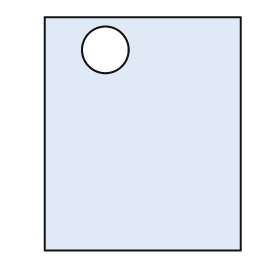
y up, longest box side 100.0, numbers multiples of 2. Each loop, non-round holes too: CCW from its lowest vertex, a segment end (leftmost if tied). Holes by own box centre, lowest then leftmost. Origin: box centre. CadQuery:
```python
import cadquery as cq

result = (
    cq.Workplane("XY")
    .moveTo(-42.0, -50.0)
    .lineTo(42.0, -50.0)
    .lineTo(42.0, 50.0)
    .lineTo(-42.0, 50.0)
    .close()
    .moveTo(-16.0, 36.0)
    .circle(10.0)
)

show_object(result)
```